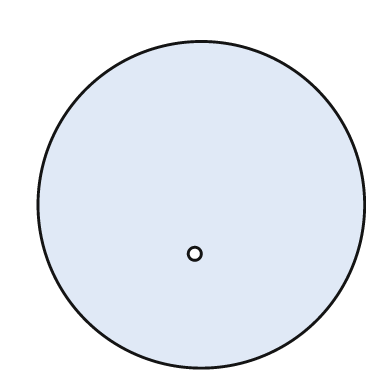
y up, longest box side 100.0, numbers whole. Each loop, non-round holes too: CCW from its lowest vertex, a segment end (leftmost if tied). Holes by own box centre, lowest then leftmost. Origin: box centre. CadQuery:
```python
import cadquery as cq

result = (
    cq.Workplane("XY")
    .moveTo(0.0, 0.0)
    .circle(50.0)
    .moveTo(-2.0, -15.0)
    .circle(2.0)
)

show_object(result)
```